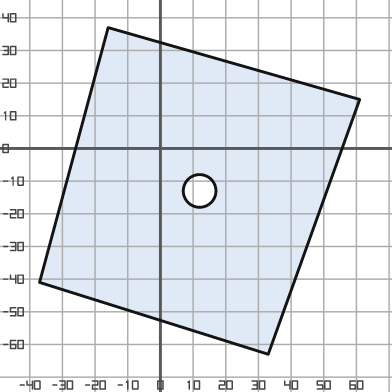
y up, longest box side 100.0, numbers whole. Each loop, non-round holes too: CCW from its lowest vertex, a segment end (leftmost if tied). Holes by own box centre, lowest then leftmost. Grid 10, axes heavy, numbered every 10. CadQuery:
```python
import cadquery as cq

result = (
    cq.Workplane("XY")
    .moveTo(33.0, -63.0)
    .lineTo(61.0, 15.0)
    .lineTo(-16.0, 37.0)
    .lineTo(-37.0, -41.0)
    .close()
    .moveTo(12.0, -13.0)
    .circle(5.0)
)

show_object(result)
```